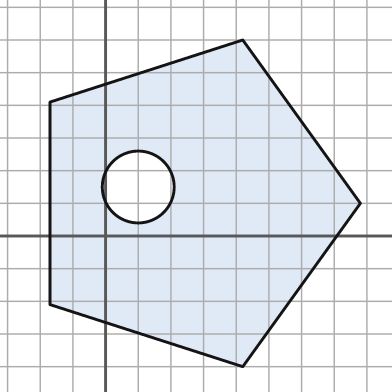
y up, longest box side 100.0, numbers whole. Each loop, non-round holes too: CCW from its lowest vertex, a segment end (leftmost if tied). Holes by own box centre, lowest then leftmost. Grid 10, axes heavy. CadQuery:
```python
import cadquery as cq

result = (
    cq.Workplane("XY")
    .moveTo(42.0, -40.0)
    .lineTo(78.0, 10.0)
    .lineTo(42.0, 60.0)
    .lineTo(-17.0, 41.0)
    .lineTo(-17.0, -21.0)
    .close()
    .moveTo(10.0, 15.0)
    .circle(11.0)
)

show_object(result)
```